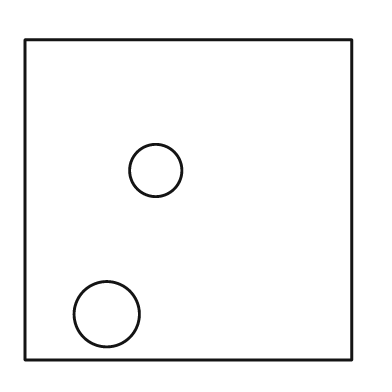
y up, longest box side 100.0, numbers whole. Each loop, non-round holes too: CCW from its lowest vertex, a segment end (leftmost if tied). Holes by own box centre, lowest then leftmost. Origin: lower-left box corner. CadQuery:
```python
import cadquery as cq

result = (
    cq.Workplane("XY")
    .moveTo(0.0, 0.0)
    .lineTo(100.0, 0.0)
    .lineTo(100.0, 98.0)
    .lineTo(0.0, 98.0)
    .close()
    .moveTo(25.0, 14.0)
    .circle(10.0)
    .moveTo(40.0, 58.0)
    .circle(8.0)
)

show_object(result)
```